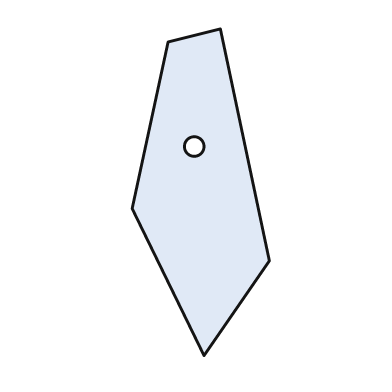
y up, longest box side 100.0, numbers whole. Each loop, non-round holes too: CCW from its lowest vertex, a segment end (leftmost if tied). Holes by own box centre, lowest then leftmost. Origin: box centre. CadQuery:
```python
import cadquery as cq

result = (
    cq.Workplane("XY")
    .moveTo(1.0, -50.0)
    .lineTo(21.0, -21.0)
    .lineTo(6.0, 50.0)
    .lineTo(-10.0, 46.0)
    .lineTo(-21.0, -5.0)
    .close()
    .moveTo(-2.0, 14.0)
    .circle(3.0)
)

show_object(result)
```